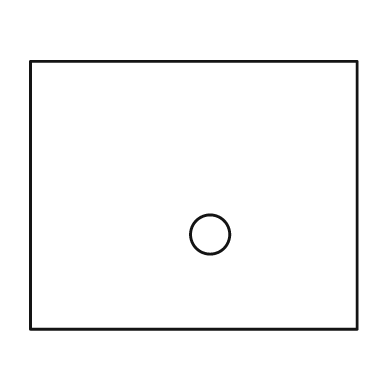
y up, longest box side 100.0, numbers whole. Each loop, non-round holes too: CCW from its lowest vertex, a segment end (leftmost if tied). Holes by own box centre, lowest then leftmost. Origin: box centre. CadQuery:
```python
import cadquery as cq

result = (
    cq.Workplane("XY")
    .moveTo(-50.0, -41.0)
    .lineTo(50.0, -41.0)
    .lineTo(50.0, 41.0)
    .lineTo(-50.0, 41.0)
    .close()
    .moveTo(5.0, -12.0)
    .circle(6.0)
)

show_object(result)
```